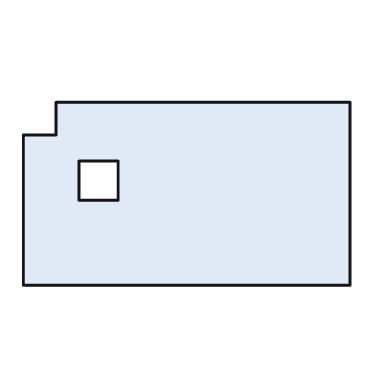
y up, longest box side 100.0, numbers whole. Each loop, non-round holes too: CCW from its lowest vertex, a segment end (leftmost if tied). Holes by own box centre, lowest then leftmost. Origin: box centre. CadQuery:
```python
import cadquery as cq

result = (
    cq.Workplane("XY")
    .moveTo(-50.0, -28.0)
    .lineTo(50.0, -28.0)
    .lineTo(50.0, 28.0)
    .lineTo(-40.0, 28.0)
    .lineTo(-40.0, 18.0)
    .lineTo(-50.0, 18.0)
    .close()
    .moveTo(-33.0, -2.0)
    .lineTo(-21.0, -2.0)
    .lineTo(-21.0, 10.0)
    .lineTo(-33.0, 10.0)
    .close()
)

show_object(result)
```